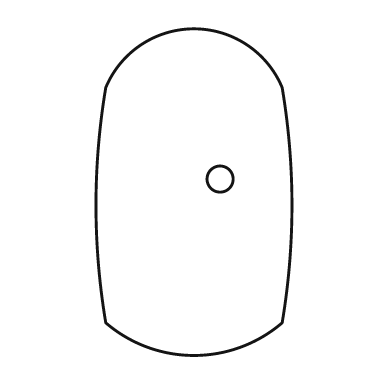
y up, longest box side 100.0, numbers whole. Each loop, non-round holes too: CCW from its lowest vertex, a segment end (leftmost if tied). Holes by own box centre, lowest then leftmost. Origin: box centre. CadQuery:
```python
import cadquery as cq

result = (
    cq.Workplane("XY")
    .moveTo(-27.0, -40.0)
    .threePointArc((0.0, -50.0), (27.0, -40.0))
    .threePointArc((30.0, -4.0), (27.0, 32.0))
    .threePointArc((0.0, 50.0), (-27.0, 32.0))
    .threePointArc((-30.0, -4.0), (-27.0, -40.0))
    .close()
    .moveTo(8.0, 4.0)
    .circle(4.0)
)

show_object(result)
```